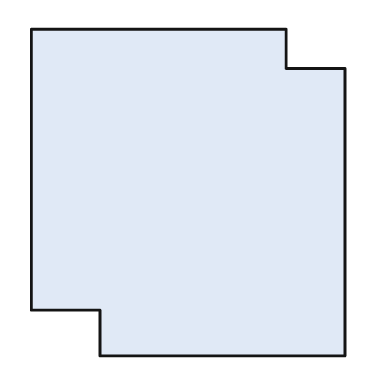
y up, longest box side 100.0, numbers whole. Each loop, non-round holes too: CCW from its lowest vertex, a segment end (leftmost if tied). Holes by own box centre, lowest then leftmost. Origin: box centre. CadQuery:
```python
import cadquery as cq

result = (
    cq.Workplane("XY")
    .moveTo(-27.0, -50.0)
    .lineTo(48.0, -50.0)
    .lineTo(48.0, 38.0)
    .lineTo(30.0, 38.0)
    .lineTo(30.0, 50.0)
    .lineTo(-48.0, 50.0)
    .lineTo(-48.0, -36.0)
    .lineTo(-27.0, -36.0)
    .close()
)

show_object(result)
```